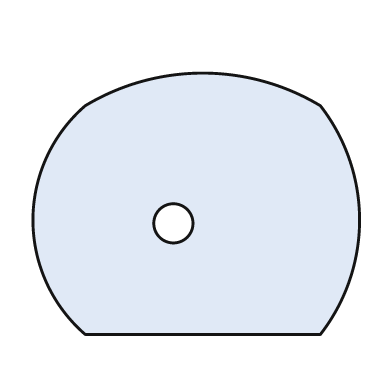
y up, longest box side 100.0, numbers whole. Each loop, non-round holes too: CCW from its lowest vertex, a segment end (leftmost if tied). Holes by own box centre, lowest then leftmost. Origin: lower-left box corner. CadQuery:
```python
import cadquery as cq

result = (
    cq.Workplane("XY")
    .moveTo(16.0, 0.0)
    .lineTo(88.0, 0.0)
    .threePointArc((100.0, 35.0), (88.0, 70.0))
    .threePointArc((52.0, 80.0), (16.0, 70.0))
    .threePointArc((0.0, 35.0), (16.0, 0.0))
    .close()
    .moveTo(43.0, 34.0)
    .circle(6.0)
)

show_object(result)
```